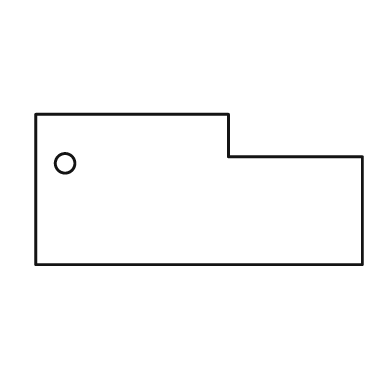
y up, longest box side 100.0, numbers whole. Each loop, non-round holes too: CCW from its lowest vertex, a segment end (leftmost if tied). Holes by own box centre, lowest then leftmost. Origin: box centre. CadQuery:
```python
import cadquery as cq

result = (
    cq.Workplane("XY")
    .moveTo(-50.0, -23.0)
    .lineTo(50.0, -23.0)
    .lineTo(50.0, 10.0)
    .lineTo(9.0, 10.0)
    .lineTo(9.0, 23.0)
    .lineTo(-50.0, 23.0)
    .close()
    .moveTo(-41.0, 8.0)
    .circle(3.0)
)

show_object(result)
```